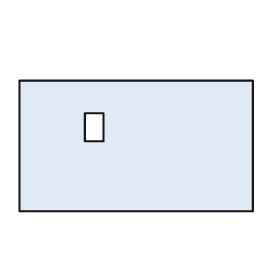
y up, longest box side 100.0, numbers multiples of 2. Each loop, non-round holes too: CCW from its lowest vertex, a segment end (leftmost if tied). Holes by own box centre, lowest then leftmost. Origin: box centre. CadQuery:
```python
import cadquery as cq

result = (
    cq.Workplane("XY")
    .moveTo(-50.0, -28.0)
    .lineTo(50.0, -28.0)
    .lineTo(50.0, 28.0)
    .lineTo(-50.0, 28.0)
    .close()
    .moveTo(-22.0, 2.0)
    .lineTo(-14.0, 2.0)
    .lineTo(-14.0, 14.0)
    .lineTo(-22.0, 14.0)
    .close()
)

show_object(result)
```